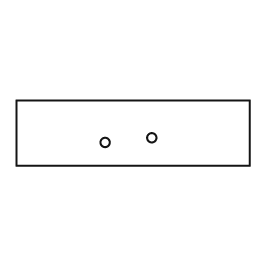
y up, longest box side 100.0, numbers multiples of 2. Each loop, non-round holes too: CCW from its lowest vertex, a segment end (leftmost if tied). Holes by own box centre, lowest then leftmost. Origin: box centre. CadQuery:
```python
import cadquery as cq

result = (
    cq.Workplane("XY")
    .moveTo(-50.0, -14.0)
    .lineTo(50.0, -14.0)
    .lineTo(50.0, 14.0)
    .lineTo(-50.0, 14.0)
    .close()
    .moveTo(-12.0, -4.0)
    .circle(2.0)
    .moveTo(8.0, -2.0)
    .circle(2.0)
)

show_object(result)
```